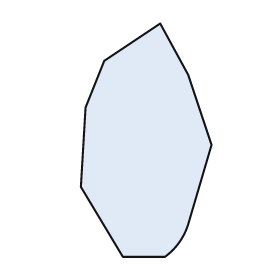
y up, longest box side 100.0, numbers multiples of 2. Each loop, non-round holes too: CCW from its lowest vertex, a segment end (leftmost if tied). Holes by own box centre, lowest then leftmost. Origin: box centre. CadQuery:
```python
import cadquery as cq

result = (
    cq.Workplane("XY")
    .moveTo(-10.0, -50.0)
    .lineTo(8.0, -50.0)
    .threePointArc((14.0, -44.0), (18.0, -36.0))
    .lineTo(28.0, -2.0)
    .lineTo(18.0, 28.0)
    .lineTo(6.0, 50.0)
    .lineTo(-18.0, 34.0)
    .lineTo(-26.0, 14.0)
    .lineTo(-28.0, -20.0)
    .close()
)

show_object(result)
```